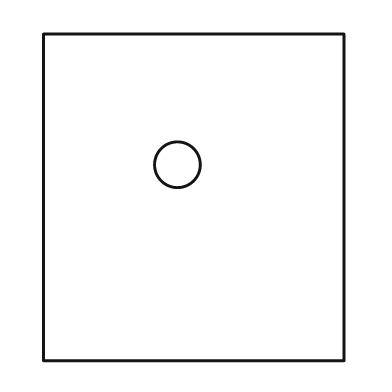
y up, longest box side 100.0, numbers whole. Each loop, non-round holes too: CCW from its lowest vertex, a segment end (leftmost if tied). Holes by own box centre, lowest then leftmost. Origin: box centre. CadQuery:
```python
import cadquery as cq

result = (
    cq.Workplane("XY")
    .moveTo(-46.0, -50.0)
    .lineTo(46.0, -50.0)
    .lineTo(46.0, 50.0)
    .lineTo(-46.0, 50.0)
    .close()
    .moveTo(-5.0, 10.0)
    .circle(7.0)
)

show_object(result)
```